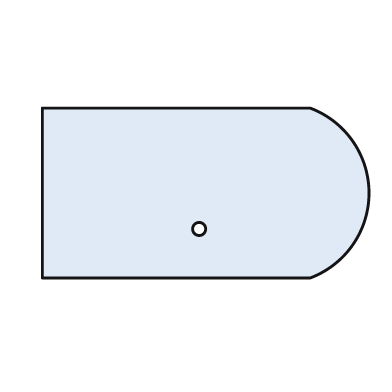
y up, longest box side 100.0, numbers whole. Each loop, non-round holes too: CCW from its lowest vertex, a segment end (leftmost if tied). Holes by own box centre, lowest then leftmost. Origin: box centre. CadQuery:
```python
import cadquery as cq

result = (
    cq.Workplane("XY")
    .moveTo(-50.0, -26.0)
    .lineTo(32.0, -26.0)
    .threePointArc((50.0, 0.0), (32.0, 26.0))
    .lineTo(-50.0, 26.0)
    .close()
    .moveTo(-2.0, -11.0)
    .circle(2.0)
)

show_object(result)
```